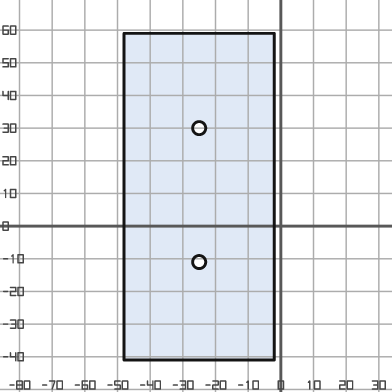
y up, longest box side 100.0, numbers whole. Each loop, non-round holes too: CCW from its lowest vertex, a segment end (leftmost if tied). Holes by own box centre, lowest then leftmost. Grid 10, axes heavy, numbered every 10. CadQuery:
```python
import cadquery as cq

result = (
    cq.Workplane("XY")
    .moveTo(-48.0, -41.0)
    .lineTo(-2.0, -41.0)
    .lineTo(-2.0, 59.0)
    .lineTo(-48.0, 59.0)
    .close()
    .moveTo(-25.0, -11.0)
    .circle(2.0)
    .moveTo(-25.0, 30.0)
    .circle(2.0)
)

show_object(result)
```